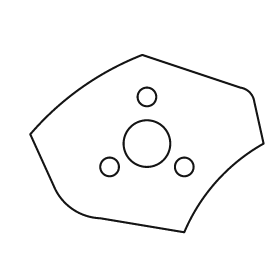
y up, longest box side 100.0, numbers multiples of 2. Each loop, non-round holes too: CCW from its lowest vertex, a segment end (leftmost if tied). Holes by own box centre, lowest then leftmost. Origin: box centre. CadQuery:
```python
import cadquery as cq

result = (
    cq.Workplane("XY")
    .moveTo(16.0, -38.0)
    .threePointArc((30.0, -16.0), (50.0, 0.0))
    .lineTo(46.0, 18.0)
    .threePointArc((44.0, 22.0), (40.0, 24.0))
    .lineTo(-2.0, 38.0)
    .threePointArc((-28.0, 24.0), (-50.0, 4.0))
    .lineTo(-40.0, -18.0)
    .threePointArc((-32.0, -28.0), (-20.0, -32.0))
    .close()
    .moveTo(-16.0, -10.0)
    .circle(4.0)
    .moveTo(16.0, -10.0)
    .circle(4.0)
    .moveTo(0.0, 0.0)
    .circle(10.0)
    .moveTo(0.0, 20.0)
    .circle(4.0)
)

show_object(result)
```